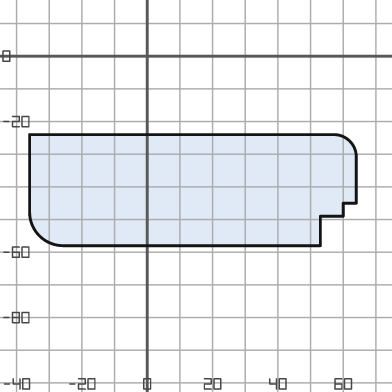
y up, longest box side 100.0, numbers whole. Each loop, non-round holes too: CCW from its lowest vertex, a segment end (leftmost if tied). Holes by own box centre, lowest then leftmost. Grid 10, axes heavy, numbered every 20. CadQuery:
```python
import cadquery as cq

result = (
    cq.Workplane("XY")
    .moveTo(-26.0, -58.0)
    .lineTo(53.0, -58.0)
    .lineTo(53.0, -49.0)
    .lineTo(60.0, -49.0)
    .lineTo(60.0, -45.0)
    .lineTo(64.0, -45.0)
    .lineTo(64.0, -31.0)
    .threePointArc((62.0, -26.0), (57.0, -24.0))
    .lineTo(-36.0, -24.0)
    .lineTo(-36.0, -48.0)
    .threePointArc((-33.0, -55.0), (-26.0, -58.0))
    .close()
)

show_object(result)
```